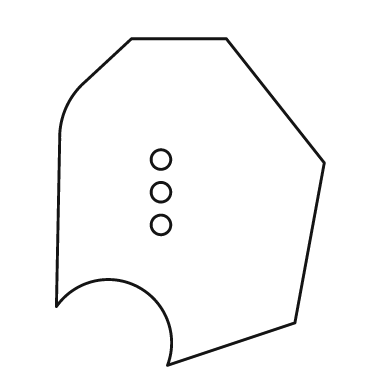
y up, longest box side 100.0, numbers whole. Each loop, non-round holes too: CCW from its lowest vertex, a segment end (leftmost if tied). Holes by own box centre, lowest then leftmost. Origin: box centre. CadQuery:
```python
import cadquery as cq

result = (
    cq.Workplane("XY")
    .moveTo(-7.0, -50.0)
    .lineTo(32.0, -37.0)
    .lineTo(41.0, 12.0)
    .lineTo(11.0, 50.0)
    .lineTo(-18.0, 50.0)
    .lineTo(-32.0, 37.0)
    .threePointArc((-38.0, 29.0), (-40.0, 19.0))
    .lineTo(-41.0, -32.0)
    .threePointArc((-16.0, -26.0), (-7.0, -50.0))
    .close()
    .moveTo(-9.0, -7.0)
    .circle(3.0)
    .moveTo(-9.0, 3.0)
    .circle(3.0)
    .moveTo(-9.0, 13.0)
    .circle(3.0)
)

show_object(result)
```